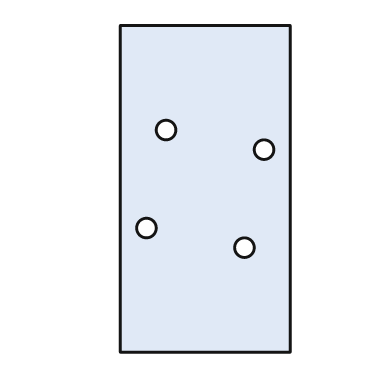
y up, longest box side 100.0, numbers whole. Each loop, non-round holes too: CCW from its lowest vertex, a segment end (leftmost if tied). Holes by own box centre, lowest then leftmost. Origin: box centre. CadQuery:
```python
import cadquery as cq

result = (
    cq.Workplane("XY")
    .moveTo(-26.0, -50.0)
    .lineTo(26.0, -50.0)
    .lineTo(26.0, 50.0)
    .lineTo(-26.0, 50.0)
    .close()
    .moveTo(12.0, -18.0)
    .circle(3.0)
    .moveTo(-18.0, -12.0)
    .circle(3.0)
    .moveTo(18.0, 12.0)
    .circle(3.0)
    .moveTo(-12.0, 18.0)
    .circle(3.0)
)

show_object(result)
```